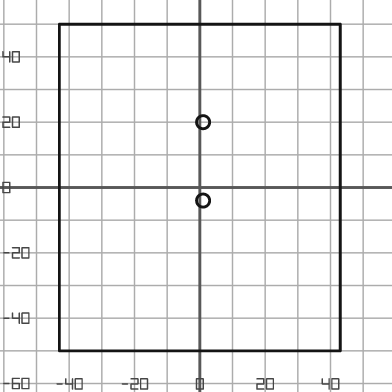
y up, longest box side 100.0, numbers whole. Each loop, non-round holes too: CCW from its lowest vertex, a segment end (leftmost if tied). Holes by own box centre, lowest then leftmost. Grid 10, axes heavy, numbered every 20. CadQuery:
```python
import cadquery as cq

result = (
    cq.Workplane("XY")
    .moveTo(-43.0, -50.0)
    .lineTo(43.0, -50.0)
    .lineTo(43.0, 50.0)
    .lineTo(-43.0, 50.0)
    .close()
    .moveTo(1.0, -4.0)
    .circle(2.0)
    .moveTo(1.0, 20.0)
    .circle(2.0)
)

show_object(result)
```